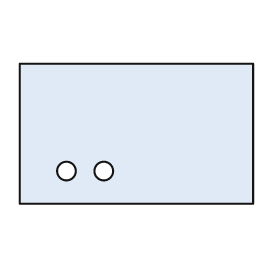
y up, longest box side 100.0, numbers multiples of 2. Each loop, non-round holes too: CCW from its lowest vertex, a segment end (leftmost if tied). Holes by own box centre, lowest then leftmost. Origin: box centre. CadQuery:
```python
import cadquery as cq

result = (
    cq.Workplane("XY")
    .moveTo(-50.0, -30.0)
    .lineTo(50.0, -30.0)
    .lineTo(50.0, 30.0)
    .lineTo(-50.0, 30.0)
    .close()
    .moveTo(-30.0, -16.0)
    .circle(4.0)
    .moveTo(-14.0, -16.0)
    .circle(4.0)
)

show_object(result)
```